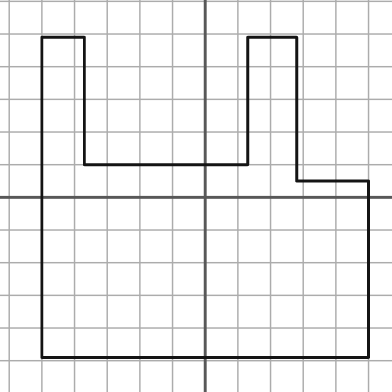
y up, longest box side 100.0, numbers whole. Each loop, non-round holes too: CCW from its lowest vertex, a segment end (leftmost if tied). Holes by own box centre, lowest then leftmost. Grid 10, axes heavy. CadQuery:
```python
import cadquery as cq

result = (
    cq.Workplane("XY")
    .moveTo(-50.0, -49.0)
    .lineTo(50.0, -49.0)
    .lineTo(50.0, 5.0)
    .lineTo(28.0, 5.0)
    .lineTo(28.0, 49.0)
    .lineTo(13.0, 49.0)
    .lineTo(13.0, 10.0)
    .lineTo(-37.0, 10.0)
    .lineTo(-37.0, 49.0)
    .lineTo(-50.0, 49.0)
    .close()
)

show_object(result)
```